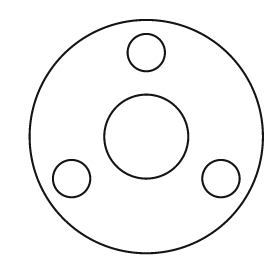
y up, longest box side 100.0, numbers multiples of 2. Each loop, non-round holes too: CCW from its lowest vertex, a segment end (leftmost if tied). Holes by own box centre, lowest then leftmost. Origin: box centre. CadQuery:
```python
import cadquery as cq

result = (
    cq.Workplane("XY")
    .moveTo(0.0, 0.0)
    .circle(50.0)
    .moveTo(-32.0, -18.0)
    .circle(8.0)
    .moveTo(32.0, -18.0)
    .circle(8.0)
    .moveTo(0.0, 0.0)
    .circle(18.0)
    .moveTo(0.0, 36.0)
    .circle(8.0)
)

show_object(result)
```